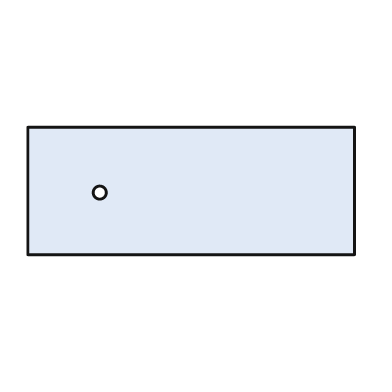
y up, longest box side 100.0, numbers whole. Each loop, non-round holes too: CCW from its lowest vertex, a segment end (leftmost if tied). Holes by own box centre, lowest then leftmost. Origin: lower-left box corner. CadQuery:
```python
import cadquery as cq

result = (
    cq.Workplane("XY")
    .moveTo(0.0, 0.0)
    .lineTo(100.0, 0.0)
    .lineTo(100.0, 39.0)
    .lineTo(0.0, 39.0)
    .close()
    .moveTo(22.0, 19.0)
    .circle(2.0)
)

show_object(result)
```